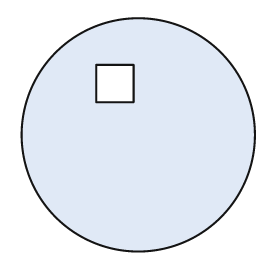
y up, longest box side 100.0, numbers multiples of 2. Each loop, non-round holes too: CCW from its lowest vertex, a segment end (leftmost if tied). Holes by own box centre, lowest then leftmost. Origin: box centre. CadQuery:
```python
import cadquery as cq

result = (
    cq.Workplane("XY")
    .moveTo(0.0, 0.0)
    .circle(50.0)
    .moveTo(-18.0, 14.0)
    .lineTo(-2.0, 14.0)
    .lineTo(-2.0, 30.0)
    .lineTo(-18.0, 30.0)
    .close()
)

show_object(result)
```